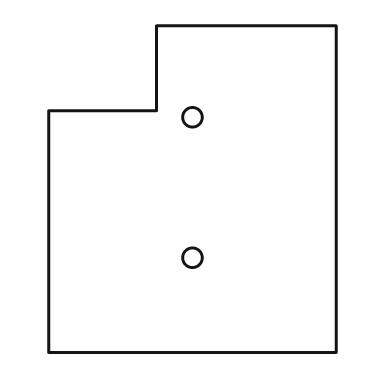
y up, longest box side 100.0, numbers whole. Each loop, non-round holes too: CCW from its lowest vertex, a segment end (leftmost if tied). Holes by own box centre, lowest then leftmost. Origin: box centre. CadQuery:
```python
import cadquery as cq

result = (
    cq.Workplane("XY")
    .moveTo(-44.0, -50.0)
    .lineTo(44.0, -50.0)
    .lineTo(44.0, 50.0)
    .lineTo(-11.0, 50.0)
    .lineTo(-11.0, 24.0)
    .lineTo(-44.0, 24.0)
    .close()
    .moveTo(0.0, -21.0)
    .circle(3.0)
    .moveTo(0.0, 22.0)
    .circle(3.0)
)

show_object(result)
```